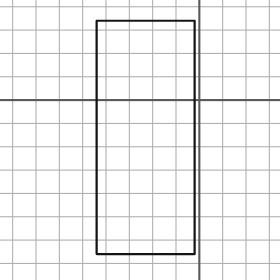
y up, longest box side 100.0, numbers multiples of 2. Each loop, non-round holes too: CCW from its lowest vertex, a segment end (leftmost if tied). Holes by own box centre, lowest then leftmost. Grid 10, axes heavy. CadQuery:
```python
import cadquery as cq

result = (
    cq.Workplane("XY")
    .moveTo(-44.0, -66.0)
    .lineTo(-2.0, -66.0)
    .lineTo(-2.0, 34.0)
    .lineTo(-44.0, 34.0)
    .close()
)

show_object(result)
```